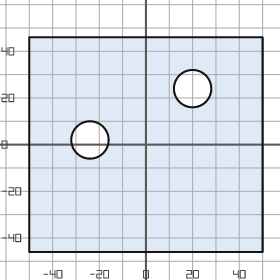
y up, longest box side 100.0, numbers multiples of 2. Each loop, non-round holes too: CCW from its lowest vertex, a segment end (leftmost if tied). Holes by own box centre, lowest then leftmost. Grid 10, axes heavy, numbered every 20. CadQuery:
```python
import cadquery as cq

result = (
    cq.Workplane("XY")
    .moveTo(-50.0, -46.0)
    .lineTo(50.0, -46.0)
    .lineTo(50.0, 46.0)
    .lineTo(-50.0, 46.0)
    .close()
    .moveTo(-24.0, 2.0)
    .circle(8.0)
    .moveTo(20.0, 24.0)
    .circle(8.0)
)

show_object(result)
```